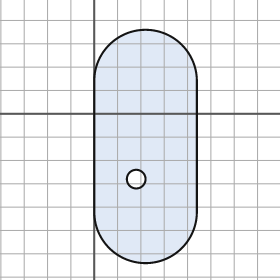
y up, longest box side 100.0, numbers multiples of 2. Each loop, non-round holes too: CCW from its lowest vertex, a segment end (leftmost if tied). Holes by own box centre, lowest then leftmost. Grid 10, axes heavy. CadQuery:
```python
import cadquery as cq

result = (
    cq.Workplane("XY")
    .moveTo(0.0, -42.0)
    .threePointArc((22.0, -64.0), (44.0, -42.0))
    .lineTo(44.0, 14.0)
    .threePointArc((22.0, 36.0), (0.0, 14.0))
    .close()
    .moveTo(18.0, -28.0)
    .circle(4.0)
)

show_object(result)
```